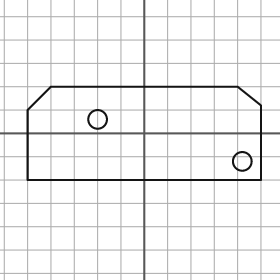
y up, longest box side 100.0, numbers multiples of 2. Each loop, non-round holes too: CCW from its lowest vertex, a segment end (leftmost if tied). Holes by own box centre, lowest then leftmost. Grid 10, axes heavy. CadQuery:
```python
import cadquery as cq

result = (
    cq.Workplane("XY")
    .moveTo(-50.0, -20.0)
    .lineTo(50.0, -20.0)
    .lineTo(50.0, 12.0)
    .lineTo(40.0, 20.0)
    .lineTo(-40.0, 20.0)
    .lineTo(-50.0, 10.0)
    .close()
    .moveTo(42.0, -12.0)
    .circle(4.0)
    .moveTo(-20.0, 6.0)
    .circle(4.0)
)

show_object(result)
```